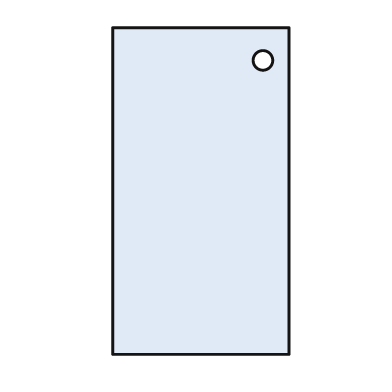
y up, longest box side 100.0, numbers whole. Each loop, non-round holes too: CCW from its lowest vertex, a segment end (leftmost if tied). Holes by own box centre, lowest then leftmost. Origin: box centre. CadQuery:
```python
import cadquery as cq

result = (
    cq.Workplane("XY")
    .moveTo(-27.0, -50.0)
    .lineTo(27.0, -50.0)
    .lineTo(27.0, 50.0)
    .lineTo(-27.0, 50.0)
    .close()
    .moveTo(19.0, 40.0)
    .circle(3.0)
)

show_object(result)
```